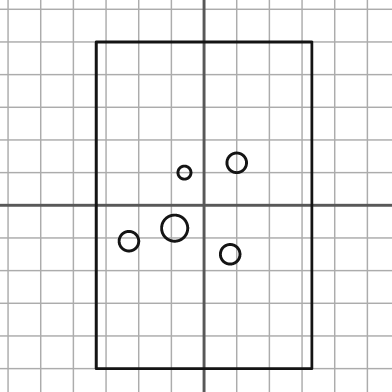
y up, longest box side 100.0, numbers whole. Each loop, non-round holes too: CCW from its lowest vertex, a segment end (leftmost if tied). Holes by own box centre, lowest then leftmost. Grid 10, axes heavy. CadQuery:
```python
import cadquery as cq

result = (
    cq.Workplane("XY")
    .moveTo(-33.0, -50.0)
    .lineTo(33.0, -50.0)
    .lineTo(33.0, 50.0)
    .lineTo(-33.0, 50.0)
    .close()
    .moveTo(8.0, -15.0)
    .circle(3.0)
    .moveTo(-23.0, -11.0)
    .circle(3.0)
    .moveTo(-9.0, -7.0)
    .circle(4.0)
    .moveTo(-6.0, 10.0)
    .circle(2.0)
    .moveTo(10.0, 13.0)
    .circle(3.0)
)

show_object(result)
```